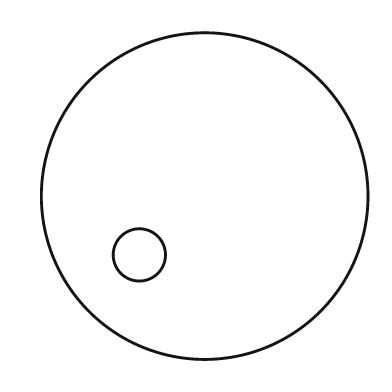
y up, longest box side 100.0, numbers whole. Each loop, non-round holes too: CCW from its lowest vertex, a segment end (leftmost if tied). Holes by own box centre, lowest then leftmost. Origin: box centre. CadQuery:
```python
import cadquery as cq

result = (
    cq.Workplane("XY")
    .moveTo(0.0, 0.0)
    .circle(50.0)
    .moveTo(-20.0, -18.0)
    .circle(8.0)
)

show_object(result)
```